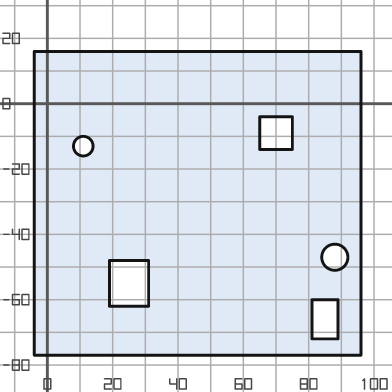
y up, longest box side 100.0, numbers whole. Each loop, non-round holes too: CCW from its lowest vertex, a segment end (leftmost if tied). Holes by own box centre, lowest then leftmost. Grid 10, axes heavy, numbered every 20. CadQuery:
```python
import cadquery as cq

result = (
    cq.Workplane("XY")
    .moveTo(-4.0, -77.0)
    .lineTo(96.0, -77.0)
    .lineTo(96.0, 16.0)
    .lineTo(-4.0, 16.0)
    .close()
    .moveTo(81.0, -72.0)
    .lineTo(89.0, -72.0)
    .lineTo(89.0, -60.0)
    .lineTo(81.0, -60.0)
    .close()
    .moveTo(19.0, -62.0)
    .lineTo(31.0, -62.0)
    .lineTo(31.0, -48.0)
    .lineTo(19.0, -48.0)
    .close()
    .moveTo(88.0, -47.0)
    .circle(4.0)
    .moveTo(11.0, -13.0)
    .circle(3.0)
    .moveTo(65.0, -14.0)
    .lineTo(75.0, -14.0)
    .lineTo(75.0, -4.0)
    .lineTo(65.0, -4.0)
    .close()
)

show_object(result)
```